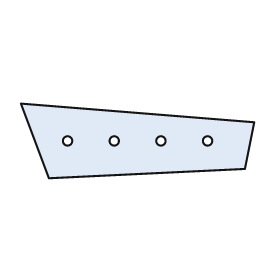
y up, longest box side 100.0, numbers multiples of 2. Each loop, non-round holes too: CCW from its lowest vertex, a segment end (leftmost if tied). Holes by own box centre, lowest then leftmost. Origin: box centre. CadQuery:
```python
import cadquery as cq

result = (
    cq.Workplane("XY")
    .moveTo(-38.0, -16.0)
    .lineTo(46.0, -12.0)
    .lineTo(50.0, 8.0)
    .lineTo(-50.0, 16.0)
    .close()
    .moveTo(-30.0, 0.0)
    .circle(2.0)
    .moveTo(-10.0, 0.0)
    .circle(2.0)
    .moveTo(10.0, 0.0)
    .circle(2.0)
    .moveTo(30.0, 0.0)
    .circle(2.0)
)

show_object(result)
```